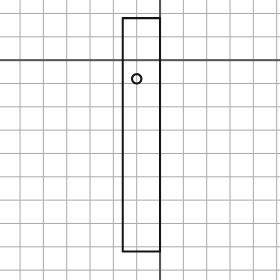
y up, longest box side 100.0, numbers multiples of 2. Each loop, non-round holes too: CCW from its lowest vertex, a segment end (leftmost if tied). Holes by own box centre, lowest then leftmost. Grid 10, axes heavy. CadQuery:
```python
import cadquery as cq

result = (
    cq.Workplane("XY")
    .moveTo(-16.0, -82.0)
    .lineTo(0.0, -82.0)
    .lineTo(0.0, 18.0)
    .lineTo(-16.0, 18.0)
    .close()
    .moveTo(-10.0, -8.0)
    .circle(2.0)
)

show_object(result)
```